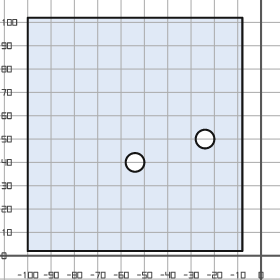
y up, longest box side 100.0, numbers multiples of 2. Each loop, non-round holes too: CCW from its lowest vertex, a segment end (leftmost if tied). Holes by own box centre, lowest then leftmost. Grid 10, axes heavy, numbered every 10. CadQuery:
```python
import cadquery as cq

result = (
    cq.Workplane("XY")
    .moveTo(-100.0, 2.0)
    .lineTo(-8.0, 2.0)
    .lineTo(-8.0, 102.0)
    .lineTo(-100.0, 102.0)
    .close()
    .moveTo(-54.0, 40.0)
    .circle(4.0)
    .moveTo(-24.0, 50.0)
    .circle(4.0)
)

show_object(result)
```